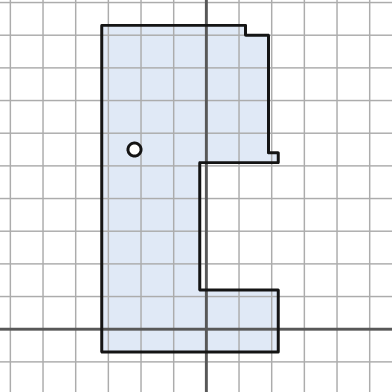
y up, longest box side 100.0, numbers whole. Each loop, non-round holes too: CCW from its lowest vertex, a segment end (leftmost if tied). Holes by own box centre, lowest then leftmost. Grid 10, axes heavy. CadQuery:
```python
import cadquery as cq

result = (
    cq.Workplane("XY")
    .moveTo(-32.0, -7.0)
    .lineTo(22.0, -7.0)
    .lineTo(22.0, 12.0)
    .lineTo(-2.0, 12.0)
    .lineTo(-2.0, 51.0)
    .lineTo(22.0, 51.0)
    .lineTo(22.0, 54.0)
    .lineTo(19.0, 54.0)
    .lineTo(19.0, 90.0)
    .lineTo(12.0, 90.0)
    .lineTo(12.0, 93.0)
    .lineTo(-32.0, 93.0)
    .close()
    .moveTo(-22.0, 55.0)
    .circle(2.0)
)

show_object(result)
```